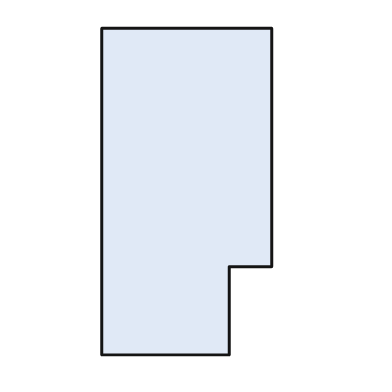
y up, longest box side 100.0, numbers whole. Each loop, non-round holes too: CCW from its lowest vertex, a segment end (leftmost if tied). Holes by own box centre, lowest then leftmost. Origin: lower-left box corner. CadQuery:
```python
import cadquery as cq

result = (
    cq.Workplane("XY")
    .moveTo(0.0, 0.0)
    .lineTo(39.0, 0.0)
    .lineTo(39.0, 27.0)
    .lineTo(52.0, 27.0)
    .lineTo(52.0, 100.0)
    .lineTo(0.0, 100.0)
    .close()
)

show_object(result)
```